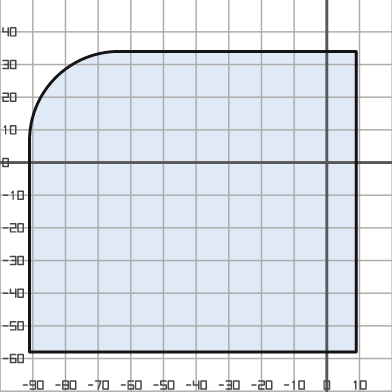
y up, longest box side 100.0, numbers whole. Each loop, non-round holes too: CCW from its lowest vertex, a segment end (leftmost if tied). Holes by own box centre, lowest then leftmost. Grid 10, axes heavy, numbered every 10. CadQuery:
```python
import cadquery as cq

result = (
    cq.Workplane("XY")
    .moveTo(-91.0, -58.0)
    .lineTo(9.0, -58.0)
    .lineTo(9.0, 34.0)
    .lineTo(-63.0, 34.0)
    .threePointArc((-83.0, 26.0), (-91.0, 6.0))
    .close()
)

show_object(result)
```